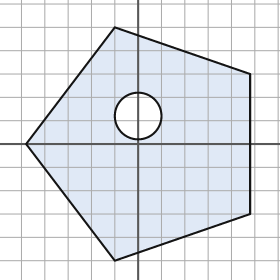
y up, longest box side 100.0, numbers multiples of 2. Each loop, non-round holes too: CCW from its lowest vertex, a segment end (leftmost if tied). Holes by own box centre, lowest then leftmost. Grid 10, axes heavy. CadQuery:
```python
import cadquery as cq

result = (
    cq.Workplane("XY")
    .moveTo(-10.0, -50.0)
    .lineTo(48.0, -30.0)
    .lineTo(48.0, 30.0)
    .lineTo(-10.0, 50.0)
    .lineTo(-48.0, 0.0)
    .close()
    .moveTo(0.0, 12.0)
    .circle(10.0)
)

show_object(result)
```